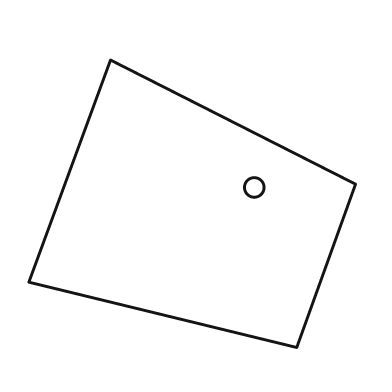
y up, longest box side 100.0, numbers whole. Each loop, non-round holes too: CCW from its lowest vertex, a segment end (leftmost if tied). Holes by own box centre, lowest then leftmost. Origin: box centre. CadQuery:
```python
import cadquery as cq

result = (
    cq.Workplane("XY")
    .moveTo(32.0, -44.0)
    .lineTo(50.0, 6.0)
    .lineTo(-25.0, 44.0)
    .lineTo(-50.0, -24.0)
    .close()
    .moveTo(19.0, 5.0)
    .circle(3.0)
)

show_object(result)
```